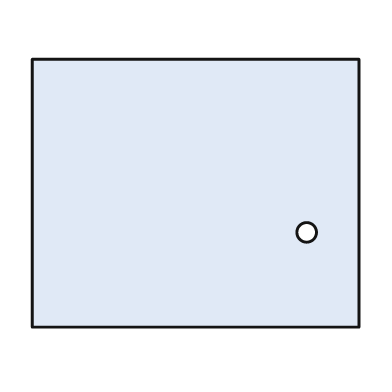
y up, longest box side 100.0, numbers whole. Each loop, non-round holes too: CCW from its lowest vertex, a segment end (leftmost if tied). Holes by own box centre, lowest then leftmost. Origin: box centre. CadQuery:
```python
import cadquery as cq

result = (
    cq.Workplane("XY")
    .moveTo(-50.0, -41.0)
    .lineTo(50.0, -41.0)
    .lineTo(50.0, 41.0)
    .lineTo(-50.0, 41.0)
    .close()
    .moveTo(34.0, -12.0)
    .circle(3.0)
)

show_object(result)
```